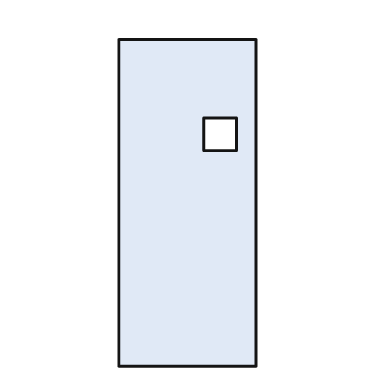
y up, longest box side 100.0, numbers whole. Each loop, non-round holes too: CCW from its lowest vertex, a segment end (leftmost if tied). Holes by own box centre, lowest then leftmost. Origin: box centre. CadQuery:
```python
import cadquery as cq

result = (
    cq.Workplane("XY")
    .moveTo(-21.0, -50.0)
    .lineTo(21.0, -50.0)
    .lineTo(21.0, 50.0)
    .lineTo(-21.0, 50.0)
    .close()
    .moveTo(5.0, 16.0)
    .lineTo(15.0, 16.0)
    .lineTo(15.0, 26.0)
    .lineTo(5.0, 26.0)
    .close()
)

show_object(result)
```